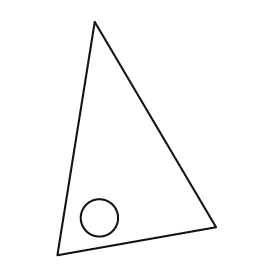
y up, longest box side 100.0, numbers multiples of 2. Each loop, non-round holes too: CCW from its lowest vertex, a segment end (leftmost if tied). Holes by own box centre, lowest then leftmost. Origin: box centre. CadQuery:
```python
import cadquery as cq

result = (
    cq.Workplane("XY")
    .moveTo(-34.0, -50.0)
    .lineTo(34.0, -38.0)
    .lineTo(-18.0, 50.0)
    .close()
    .moveTo(-16.0, -34.0)
    .circle(8.0)
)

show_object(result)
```